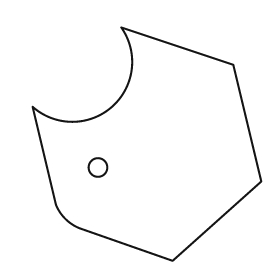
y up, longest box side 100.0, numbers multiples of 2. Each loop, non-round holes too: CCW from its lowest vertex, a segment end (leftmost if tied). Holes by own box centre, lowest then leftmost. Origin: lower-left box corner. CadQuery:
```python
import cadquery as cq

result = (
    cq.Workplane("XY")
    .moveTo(60.0, 0.0)
    .lineTo(98.0, 34.0)
    .lineTo(86.0, 84.0)
    .lineTo(38.0, 100.0)
    .threePointArc((34.0, 66.0), (0.0, 66.0))
    .lineTo(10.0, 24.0)
    .threePointArc((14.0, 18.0), (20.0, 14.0))
    .close()
    .moveTo(28.0, 40.0)
    .circle(4.0)
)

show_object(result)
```